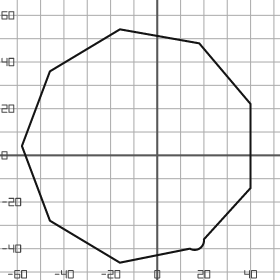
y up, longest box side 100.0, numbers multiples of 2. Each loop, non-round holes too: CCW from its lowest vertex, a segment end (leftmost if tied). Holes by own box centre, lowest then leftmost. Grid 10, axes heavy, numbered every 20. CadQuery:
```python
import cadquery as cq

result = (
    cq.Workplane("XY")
    .moveTo(-16.0, -46.0)
    .lineTo(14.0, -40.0)
    .threePointArc((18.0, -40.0), (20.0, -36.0))
    .lineTo(40.0, -14.0)
    .lineTo(40.0, 22.0)
    .lineTo(18.0, 48.0)
    .lineTo(-16.0, 54.0)
    .lineTo(-46.0, 36.0)
    .lineTo(-58.0, 4.0)
    .lineTo(-46.0, -28.0)
    .close()
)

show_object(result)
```